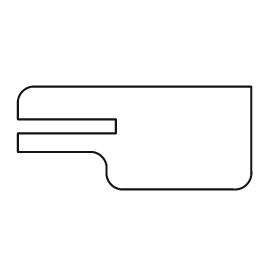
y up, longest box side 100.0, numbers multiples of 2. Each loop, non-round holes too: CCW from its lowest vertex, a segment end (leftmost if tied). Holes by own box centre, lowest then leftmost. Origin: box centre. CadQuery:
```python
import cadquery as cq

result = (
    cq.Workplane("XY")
    .moveTo(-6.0, -22.0)
    .lineTo(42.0, -22.0)
    .threePointArc((48.0, -20.0), (50.0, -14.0))
    .lineTo(50.0, 22.0)
    .lineTo(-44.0, 22.0)
    .threePointArc((-48.0, 20.0), (-50.0, 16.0))
    .lineTo(-50.0, 8.0)
    .lineTo(-8.0, 8.0)
    .lineTo(-8.0, 2.0)
    .lineTo(-50.0, 2.0)
    .lineTo(-50.0, -6.0)
    .lineTo(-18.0, -6.0)
    .threePointArc((-14.0, -8.0), (-12.0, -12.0))
    .lineTo(-12.0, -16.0)
    .threePointArc((-10.0, -20.0), (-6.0, -22.0))
    .close()
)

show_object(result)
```